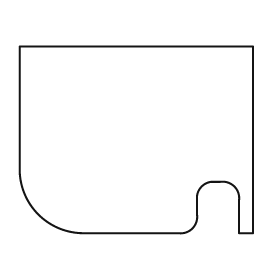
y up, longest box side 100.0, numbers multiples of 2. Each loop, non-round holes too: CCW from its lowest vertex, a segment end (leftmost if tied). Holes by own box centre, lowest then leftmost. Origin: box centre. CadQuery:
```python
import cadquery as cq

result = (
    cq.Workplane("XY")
    .moveTo(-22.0, -40.0)
    .lineTo(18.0, -40.0)
    .threePointArc((24.0, -38.0), (26.0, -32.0))
    .lineTo(26.0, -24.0)
    .threePointArc((28.0, -20.0), (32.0, -18.0))
    .lineTo(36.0, -18.0)
    .threePointArc((42.0, -20.0), (44.0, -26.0))
    .lineTo(44.0, -40.0)
    .lineTo(50.0, -40.0)
    .lineTo(50.0, 40.0)
    .lineTo(-50.0, 40.0)
    .lineTo(-50.0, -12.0)
    .threePointArc((-42.0, -32.0), (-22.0, -40.0))
    .close()
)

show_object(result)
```